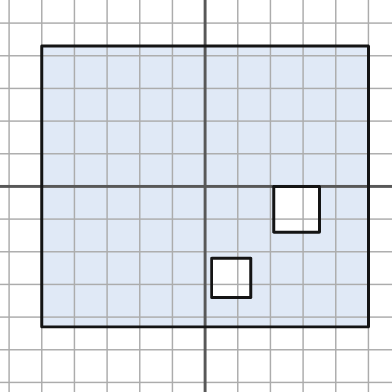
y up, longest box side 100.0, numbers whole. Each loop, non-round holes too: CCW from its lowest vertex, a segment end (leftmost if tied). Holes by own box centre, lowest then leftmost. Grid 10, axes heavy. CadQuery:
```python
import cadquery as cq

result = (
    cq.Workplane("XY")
    .moveTo(-50.0, -43.0)
    .lineTo(50.0, -43.0)
    .lineTo(50.0, 43.0)
    .lineTo(-50.0, 43.0)
    .close()
    .moveTo(2.0, -34.0)
    .lineTo(14.0, -34.0)
    .lineTo(14.0, -22.0)
    .lineTo(2.0, -22.0)
    .close()
    .moveTo(21.0, -14.0)
    .lineTo(35.0, -14.0)
    .lineTo(35.0, 0.0)
    .lineTo(21.0, 0.0)
    .close()
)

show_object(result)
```